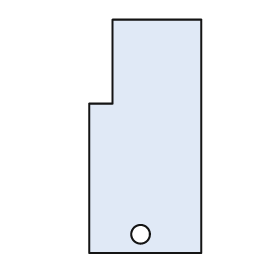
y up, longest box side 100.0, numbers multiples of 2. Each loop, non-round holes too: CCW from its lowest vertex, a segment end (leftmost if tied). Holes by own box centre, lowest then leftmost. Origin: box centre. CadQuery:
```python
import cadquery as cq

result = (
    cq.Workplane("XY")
    .moveTo(-24.0, -50.0)
    .lineTo(24.0, -50.0)
    .lineTo(24.0, 50.0)
    .lineTo(-14.0, 50.0)
    .lineTo(-14.0, 14.0)
    .lineTo(-24.0, 14.0)
    .close()
    .moveTo(-2.0, -42.0)
    .circle(4.0)
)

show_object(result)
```